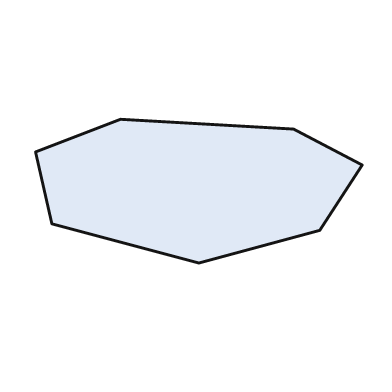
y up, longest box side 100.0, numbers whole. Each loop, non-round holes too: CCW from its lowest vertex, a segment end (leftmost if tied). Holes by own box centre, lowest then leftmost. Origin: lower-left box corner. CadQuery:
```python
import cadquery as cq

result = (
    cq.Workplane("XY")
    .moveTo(50.0, 0.0)
    .lineTo(87.0, 10.0)
    .lineTo(100.0, 30.0)
    .lineTo(79.0, 41.0)
    .lineTo(26.0, 44.0)
    .lineTo(0.0, 34.0)
    .lineTo(5.0, 12.0)
    .close()
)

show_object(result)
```